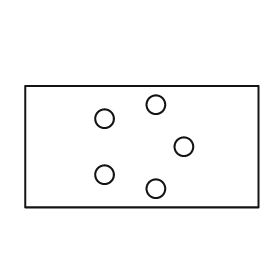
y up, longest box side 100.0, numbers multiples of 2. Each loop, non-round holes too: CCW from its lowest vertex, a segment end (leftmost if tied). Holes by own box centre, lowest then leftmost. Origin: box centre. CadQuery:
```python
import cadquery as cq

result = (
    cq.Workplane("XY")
    .moveTo(-50.0, -26.0)
    .lineTo(50.0, -26.0)
    .lineTo(50.0, 26.0)
    .lineTo(-50.0, 26.0)
    .close()
    .moveTo(6.0, -18.0)
    .circle(4.0)
    .moveTo(-16.0, -12.0)
    .circle(4.0)
    .moveTo(18.0, 0.0)
    .circle(4.0)
    .moveTo(-16.0, 12.0)
    .circle(4.0)
    .moveTo(6.0, 18.0)
    .circle(4.0)
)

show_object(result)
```